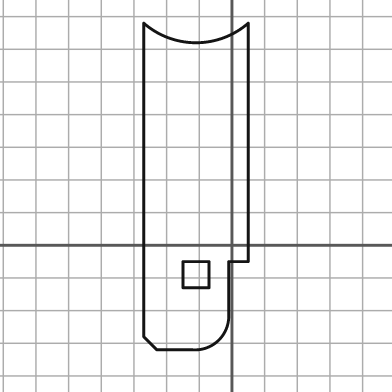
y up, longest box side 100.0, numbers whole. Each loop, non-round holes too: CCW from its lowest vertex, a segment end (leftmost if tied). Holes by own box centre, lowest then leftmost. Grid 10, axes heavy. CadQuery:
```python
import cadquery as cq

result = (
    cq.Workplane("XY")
    .moveTo(-23.0, -32.0)
    .lineTo(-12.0, -32.0)
    .threePointArc((-4.0, -29.0), (-1.0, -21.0))
    .lineTo(-1.0, -5.0)
    .lineTo(5.0, -5.0)
    .lineTo(5.0, 68.0)
    .threePointArc((-11.0, 62.0), (-27.0, 68.0))
    .lineTo(-27.0, -28.0)
    .close()
    .moveTo(-15.0, -13.0)
    .lineTo(-7.0, -13.0)
    .lineTo(-7.0, -5.0)
    .lineTo(-15.0, -5.0)
    .close()
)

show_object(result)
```